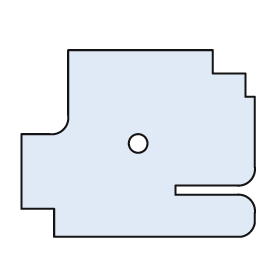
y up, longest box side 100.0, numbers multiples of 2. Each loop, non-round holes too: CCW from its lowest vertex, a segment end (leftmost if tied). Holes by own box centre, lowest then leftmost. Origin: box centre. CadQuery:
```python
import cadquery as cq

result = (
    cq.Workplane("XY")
    .moveTo(-36.0, -40.0)
    .lineTo(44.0, -40.0)
    .threePointArc((48.0, -38.0), (50.0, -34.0))
    .lineTo(50.0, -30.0)
    .threePointArc((48.0, -24.0), (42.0, -22.0))
    .lineTo(16.0, -22.0)
    .lineTo(16.0, -18.0)
    .lineTo(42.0, -18.0)
    .threePointArc((48.0, -16.0), (50.0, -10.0))
    .lineTo(50.0, 20.0)
    .lineTo(46.0, 20.0)
    .lineTo(46.0, 30.0)
    .lineTo(32.0, 30.0)
    .lineTo(32.0, 40.0)
    .lineTo(-30.0, 40.0)
    .lineTo(-30.0, 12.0)
    .threePointArc((-32.0, 6.0), (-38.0, 4.0))
    .lineTo(-50.0, 4.0)
    .lineTo(-50.0, -28.0)
    .lineTo(-36.0, -28.0)
    .close()
    .moveTo(0.0, 0.0)
    .circle(4.0)
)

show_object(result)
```